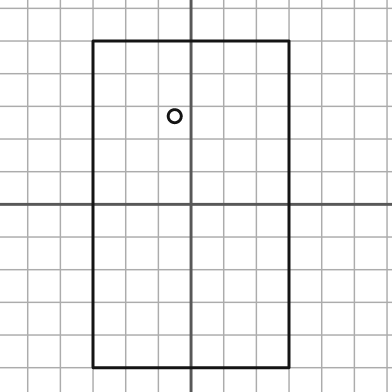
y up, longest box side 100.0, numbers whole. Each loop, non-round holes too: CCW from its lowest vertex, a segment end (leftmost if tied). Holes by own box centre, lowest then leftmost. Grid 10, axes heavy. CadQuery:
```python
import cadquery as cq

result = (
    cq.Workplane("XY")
    .moveTo(-30.0, -50.0)
    .lineTo(30.0, -50.0)
    .lineTo(30.0, 50.0)
    .lineTo(-30.0, 50.0)
    .close()
    .moveTo(-5.0, 27.0)
    .circle(2.0)
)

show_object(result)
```